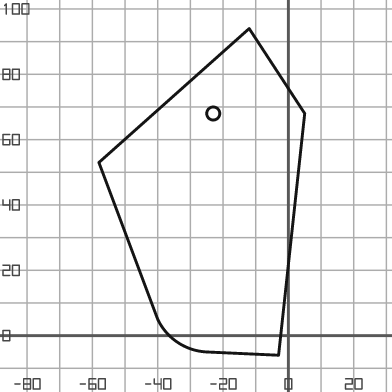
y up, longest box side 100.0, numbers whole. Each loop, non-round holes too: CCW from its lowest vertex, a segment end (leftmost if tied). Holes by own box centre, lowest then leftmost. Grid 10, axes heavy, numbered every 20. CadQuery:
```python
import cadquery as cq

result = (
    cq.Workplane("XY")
    .moveTo(-3.0, -6.0)
    .lineTo(5.0, 68.0)
    .lineTo(-12.0, 94.0)
    .lineTo(-58.0, 53.0)
    .lineTo(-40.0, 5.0)
    .threePointArc((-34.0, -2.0), (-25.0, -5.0))
    .close()
    .moveTo(-23.0, 68.0)
    .circle(2.0)
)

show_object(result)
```